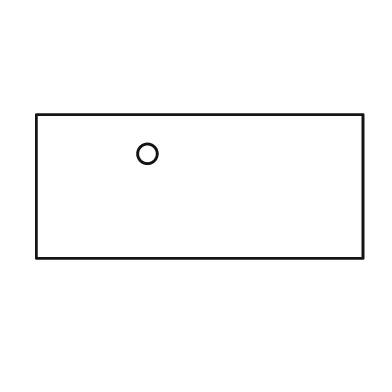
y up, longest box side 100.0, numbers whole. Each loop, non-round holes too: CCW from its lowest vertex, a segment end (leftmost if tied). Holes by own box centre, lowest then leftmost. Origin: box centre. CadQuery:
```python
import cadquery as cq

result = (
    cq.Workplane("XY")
    .moveTo(-50.0, -22.0)
    .lineTo(50.0, -22.0)
    .lineTo(50.0, 22.0)
    .lineTo(-50.0, 22.0)
    .close()
    .moveTo(-16.0, 10.0)
    .circle(3.0)
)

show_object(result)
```